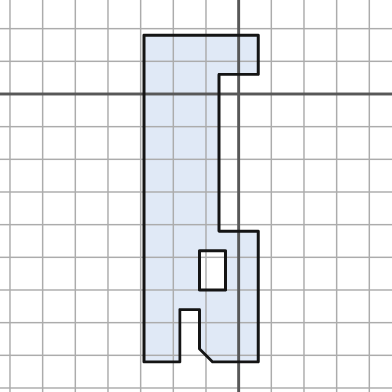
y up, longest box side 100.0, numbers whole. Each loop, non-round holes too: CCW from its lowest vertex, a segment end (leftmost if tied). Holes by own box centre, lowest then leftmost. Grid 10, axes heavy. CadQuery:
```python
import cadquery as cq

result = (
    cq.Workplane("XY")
    .moveTo(-29.0, -82.0)
    .lineTo(-18.0, -82.0)
    .lineTo(-18.0, -66.0)
    .lineTo(-12.0, -66.0)
    .lineTo(-12.0, -78.0)
    .lineTo(-8.0, -82.0)
    .lineTo(6.0, -82.0)
    .lineTo(6.0, -42.0)
    .lineTo(-6.0, -42.0)
    .lineTo(-6.0, 6.0)
    .lineTo(6.0, 6.0)
    .lineTo(6.0, 18.0)
    .lineTo(-29.0, 18.0)
    .close()
    .moveTo(-12.0, -60.0)
    .lineTo(-4.0, -60.0)
    .lineTo(-4.0, -48.0)
    .lineTo(-12.0, -48.0)
    .close()
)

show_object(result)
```